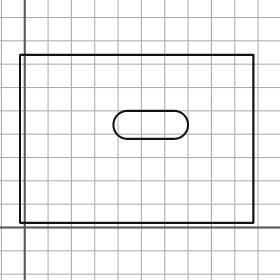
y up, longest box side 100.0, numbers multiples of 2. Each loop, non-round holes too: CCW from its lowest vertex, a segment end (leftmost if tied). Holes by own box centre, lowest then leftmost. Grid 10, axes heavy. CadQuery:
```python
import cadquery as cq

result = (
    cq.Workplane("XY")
    .moveTo(-2.0, 2.0)
    .lineTo(98.0, 2.0)
    .lineTo(98.0, 74.0)
    .lineTo(-2.0, 74.0)
    .close()
    .moveTo(44.0, 38.0)
    .lineTo(64.0, 38.0)
    .threePointArc((70.0, 44.0), (64.0, 50.0))
    .lineTo(44.0, 50.0)
    .threePointArc((38.0, 44.0), (44.0, 38.0))
    .close()
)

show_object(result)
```